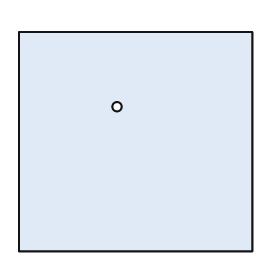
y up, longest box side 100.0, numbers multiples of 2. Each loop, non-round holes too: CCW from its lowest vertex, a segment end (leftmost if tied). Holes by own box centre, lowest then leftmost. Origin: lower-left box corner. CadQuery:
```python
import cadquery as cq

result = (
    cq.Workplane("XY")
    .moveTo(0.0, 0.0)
    .lineTo(100.0, 0.0)
    .lineTo(100.0, 94.0)
    .lineTo(0.0, 94.0)
    .close()
    .moveTo(42.0, 62.0)
    .circle(2.0)
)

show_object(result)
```